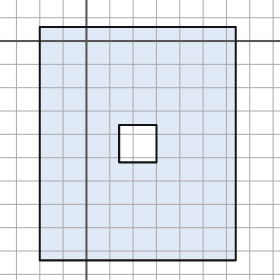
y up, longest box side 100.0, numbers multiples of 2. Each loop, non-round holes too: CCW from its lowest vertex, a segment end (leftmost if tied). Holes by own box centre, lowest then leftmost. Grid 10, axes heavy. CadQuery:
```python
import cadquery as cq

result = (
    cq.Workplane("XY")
    .moveTo(-20.0, -94.0)
    .lineTo(64.0, -94.0)
    .lineTo(64.0, 6.0)
    .lineTo(-20.0, 6.0)
    .close()
    .moveTo(14.0, -52.0)
    .lineTo(30.0, -52.0)
    .lineTo(30.0, -36.0)
    .lineTo(14.0, -36.0)
    .close()
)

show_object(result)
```